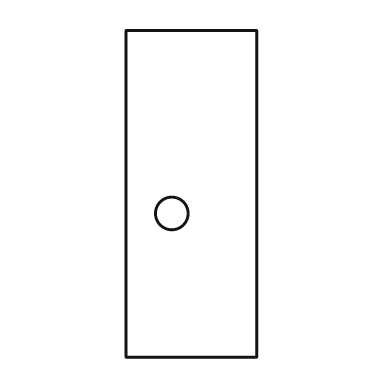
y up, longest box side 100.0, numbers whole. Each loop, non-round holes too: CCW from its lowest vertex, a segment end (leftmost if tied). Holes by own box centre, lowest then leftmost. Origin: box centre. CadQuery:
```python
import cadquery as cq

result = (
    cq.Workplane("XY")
    .moveTo(-20.0, -50.0)
    .lineTo(20.0, -50.0)
    .lineTo(20.0, 50.0)
    .lineTo(-20.0, 50.0)
    .close()
    .moveTo(-6.0, -6.0)
    .circle(5.0)
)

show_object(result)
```